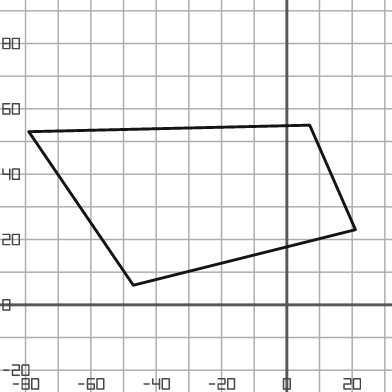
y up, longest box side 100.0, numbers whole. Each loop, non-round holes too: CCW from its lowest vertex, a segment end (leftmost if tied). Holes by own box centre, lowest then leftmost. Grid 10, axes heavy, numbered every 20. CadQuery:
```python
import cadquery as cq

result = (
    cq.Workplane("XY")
    .moveTo(-47.0, 6.0)
    .lineTo(21.0, 23.0)
    .lineTo(7.0, 55.0)
    .lineTo(-79.0, 53.0)
    .close()
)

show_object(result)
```